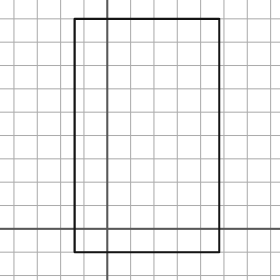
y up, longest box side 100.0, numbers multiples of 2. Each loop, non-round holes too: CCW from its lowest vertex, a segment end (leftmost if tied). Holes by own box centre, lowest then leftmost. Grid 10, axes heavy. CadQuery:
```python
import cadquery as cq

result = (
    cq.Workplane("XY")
    .moveTo(-14.0, -10.0)
    .lineTo(48.0, -10.0)
    .lineTo(48.0, 90.0)
    .lineTo(-14.0, 90.0)
    .close()
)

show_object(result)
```